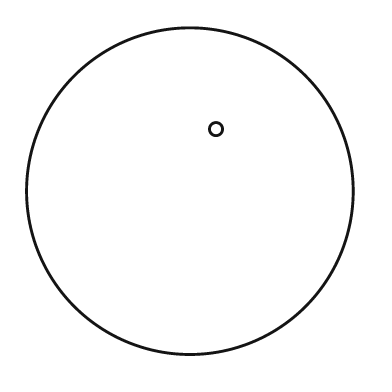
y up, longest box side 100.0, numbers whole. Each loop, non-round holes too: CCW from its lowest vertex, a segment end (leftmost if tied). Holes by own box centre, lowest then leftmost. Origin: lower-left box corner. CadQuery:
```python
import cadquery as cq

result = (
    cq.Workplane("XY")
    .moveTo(50.0, 50.0)
    .circle(50.0)
    .moveTo(58.0, 69.0)
    .circle(2.0)
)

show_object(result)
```